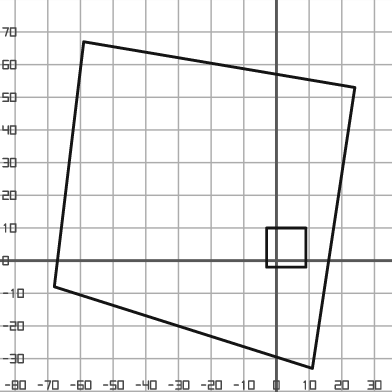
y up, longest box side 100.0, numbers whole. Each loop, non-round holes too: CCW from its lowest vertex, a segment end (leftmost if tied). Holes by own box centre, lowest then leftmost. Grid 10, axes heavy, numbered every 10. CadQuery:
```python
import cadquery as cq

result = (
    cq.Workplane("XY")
    .moveTo(11.0, -33.0)
    .lineTo(24.0, 53.0)
    .lineTo(-59.0, 67.0)
    .lineTo(-68.0, -8.0)
    .close()
    .moveTo(-3.0, -2.0)
    .lineTo(9.0, -2.0)
    .lineTo(9.0, 10.0)
    .lineTo(-3.0, 10.0)
    .close()
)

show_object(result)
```